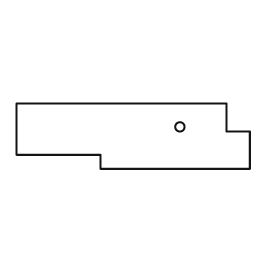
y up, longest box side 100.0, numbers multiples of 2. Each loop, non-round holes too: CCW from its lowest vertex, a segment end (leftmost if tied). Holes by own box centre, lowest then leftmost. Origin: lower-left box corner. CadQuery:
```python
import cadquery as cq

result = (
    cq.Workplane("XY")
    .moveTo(36.0, 0.0)
    .lineTo(100.0, 0.0)
    .lineTo(100.0, 16.0)
    .lineTo(90.0, 16.0)
    .lineTo(90.0, 28.0)
    .lineTo(0.0, 28.0)
    .lineTo(0.0, 6.0)
    .lineTo(36.0, 6.0)
    .close()
    .moveTo(70.0, 18.0)
    .circle(2.0)
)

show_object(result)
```